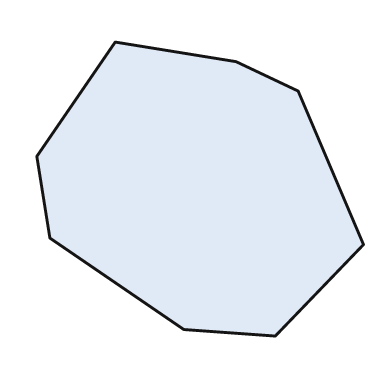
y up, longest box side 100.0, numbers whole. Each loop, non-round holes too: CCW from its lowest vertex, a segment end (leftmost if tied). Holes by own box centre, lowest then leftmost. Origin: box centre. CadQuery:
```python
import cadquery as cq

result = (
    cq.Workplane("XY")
    .moveTo(23.0, -45.0)
    .lineTo(50.0, -17.0)
    .lineTo(30.0, 30.0)
    .lineTo(11.0, 39.0)
    .lineTo(-26.0, 45.0)
    .lineTo(-50.0, 10.0)
    .lineTo(-46.0, -15.0)
    .lineTo(-5.0, -43.0)
    .close()
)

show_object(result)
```